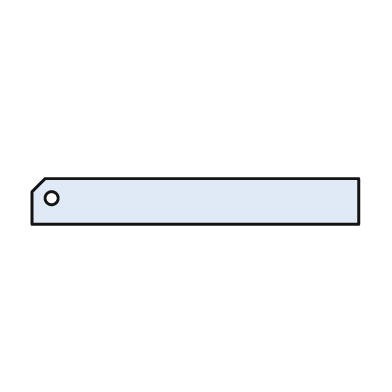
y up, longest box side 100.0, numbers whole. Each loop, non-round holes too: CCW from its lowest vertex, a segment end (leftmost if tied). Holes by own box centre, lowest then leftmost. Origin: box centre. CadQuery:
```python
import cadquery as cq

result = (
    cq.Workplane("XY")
    .moveTo(-50.0, -7.0)
    .lineTo(50.0, -7.0)
    .lineTo(50.0, 7.0)
    .lineTo(-46.0, 7.0)
    .lineTo(-50.0, 3.0)
    .close()
    .moveTo(-44.0, 1.0)
    .circle(2.0)
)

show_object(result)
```